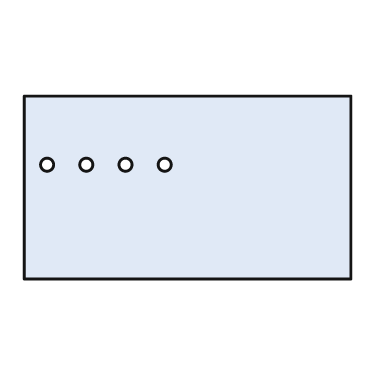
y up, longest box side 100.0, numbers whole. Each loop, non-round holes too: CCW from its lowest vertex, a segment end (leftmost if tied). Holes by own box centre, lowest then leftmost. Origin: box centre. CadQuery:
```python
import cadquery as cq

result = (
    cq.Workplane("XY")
    .moveTo(-50.0, -28.0)
    .lineTo(50.0, -28.0)
    .lineTo(50.0, 28.0)
    .lineTo(-50.0, 28.0)
    .close()
    .moveTo(-43.0, 7.0)
    .circle(2.0)
    .moveTo(-31.0, 7.0)
    .circle(2.0)
    .moveTo(-19.0, 7.0)
    .circle(2.0)
    .moveTo(-7.0, 7.0)
    .circle(2.0)
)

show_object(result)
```